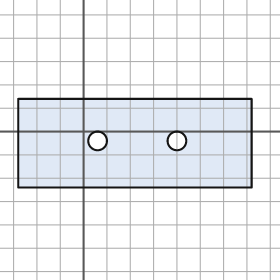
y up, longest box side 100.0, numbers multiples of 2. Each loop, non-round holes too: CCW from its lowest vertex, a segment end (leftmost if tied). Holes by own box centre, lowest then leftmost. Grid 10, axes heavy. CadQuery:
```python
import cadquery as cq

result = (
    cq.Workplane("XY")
    .moveTo(-28.0, -24.0)
    .lineTo(72.0, -24.0)
    .lineTo(72.0, 14.0)
    .lineTo(-28.0, 14.0)
    .close()
    .moveTo(6.0, -4.0)
    .circle(4.0)
    .moveTo(40.0, -4.0)
    .circle(4.0)
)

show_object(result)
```